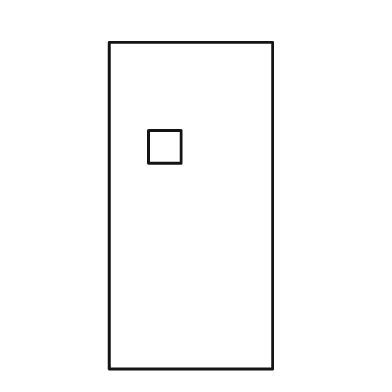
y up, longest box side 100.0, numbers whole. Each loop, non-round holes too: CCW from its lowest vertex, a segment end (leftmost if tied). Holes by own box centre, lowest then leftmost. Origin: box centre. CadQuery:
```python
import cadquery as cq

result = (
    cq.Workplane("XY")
    .moveTo(-25.0, -50.0)
    .lineTo(25.0, -50.0)
    .lineTo(25.0, 50.0)
    .lineTo(-25.0, 50.0)
    .close()
    .moveTo(-13.0, 13.0)
    .lineTo(-3.0, 13.0)
    .lineTo(-3.0, 23.0)
    .lineTo(-13.0, 23.0)
    .close()
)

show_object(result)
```